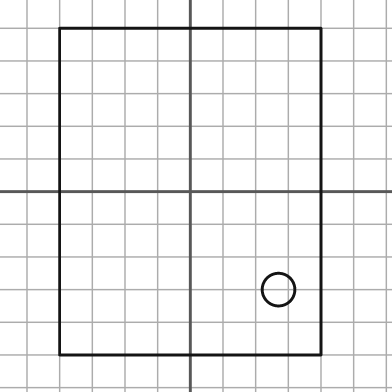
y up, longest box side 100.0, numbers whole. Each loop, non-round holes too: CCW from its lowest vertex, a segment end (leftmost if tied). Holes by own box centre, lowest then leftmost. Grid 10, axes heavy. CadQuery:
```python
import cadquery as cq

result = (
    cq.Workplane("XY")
    .moveTo(-40.0, -50.0)
    .lineTo(40.0, -50.0)
    .lineTo(40.0, 50.0)
    .lineTo(-40.0, 50.0)
    .close()
    .moveTo(27.0, -30.0)
    .circle(5.0)
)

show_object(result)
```